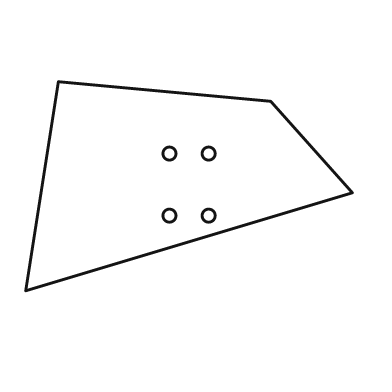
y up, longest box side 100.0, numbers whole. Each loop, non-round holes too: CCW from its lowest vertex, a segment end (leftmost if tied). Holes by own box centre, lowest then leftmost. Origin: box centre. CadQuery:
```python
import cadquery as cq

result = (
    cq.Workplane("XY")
    .moveTo(-50.0, -32.0)
    .lineTo(50.0, -2.0)
    .lineTo(25.0, 26.0)
    .lineTo(-40.0, 32.0)
    .close()
    .moveTo(-6.0, -9.0)
    .circle(2.0)
    .moveTo(6.0, -9.0)
    .circle(2.0)
    .moveTo(-6.0, 10.0)
    .circle(2.0)
    .moveTo(6.0, 10.0)
    .circle(2.0)
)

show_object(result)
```